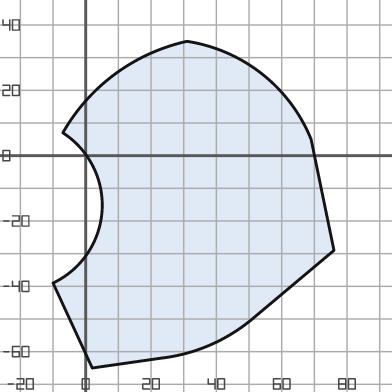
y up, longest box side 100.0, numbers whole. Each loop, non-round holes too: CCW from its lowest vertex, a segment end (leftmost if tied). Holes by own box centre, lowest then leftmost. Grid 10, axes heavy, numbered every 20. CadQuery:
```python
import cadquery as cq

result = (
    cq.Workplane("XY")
    .moveTo(2.0, -65.0)
    .lineTo(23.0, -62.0)
    .threePointArc((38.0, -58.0), (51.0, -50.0))
    .lineTo(76.0, -29.0)
    .lineTo(69.0, 5.0)
    .threePointArc((54.0, 25.0), (31.0, 35.0))
    .threePointArc((9.0, 25.0), (-7.0, 7.0))
    .threePointArc((5.0, -17.0), (-10.0, -39.0))
    .close()
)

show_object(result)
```